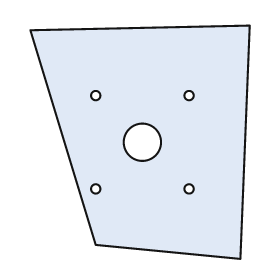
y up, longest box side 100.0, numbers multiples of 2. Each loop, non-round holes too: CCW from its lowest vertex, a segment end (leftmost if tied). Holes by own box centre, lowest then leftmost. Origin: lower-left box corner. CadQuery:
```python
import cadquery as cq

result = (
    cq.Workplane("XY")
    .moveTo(90.0, 0.0)
    .lineTo(94.0, 100.0)
    .lineTo(0.0, 98.0)
    .lineTo(28.0, 6.0)
    .close()
    .moveTo(28.0, 30.0)
    .circle(2.0)
    .moveTo(68.0, 30.0)
    .circle(2.0)
    .moveTo(48.0, 50.0)
    .circle(8.0)
    .moveTo(28.0, 70.0)
    .circle(2.0)
    .moveTo(68.0, 70.0)
    .circle(2.0)
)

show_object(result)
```